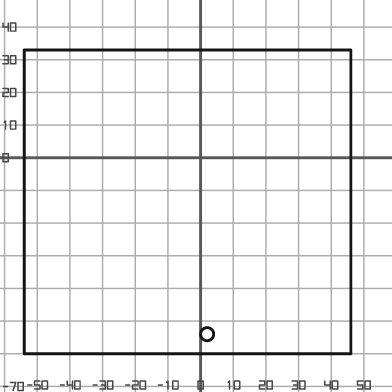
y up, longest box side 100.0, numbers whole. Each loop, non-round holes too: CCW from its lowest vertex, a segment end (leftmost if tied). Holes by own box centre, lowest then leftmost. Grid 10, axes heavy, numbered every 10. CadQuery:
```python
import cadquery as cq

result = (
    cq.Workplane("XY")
    .moveTo(-54.0, -60.0)
    .lineTo(46.0, -60.0)
    .lineTo(46.0, 33.0)
    .lineTo(-54.0, 33.0)
    .close()
    .moveTo(2.0, -54.0)
    .circle(2.0)
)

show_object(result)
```